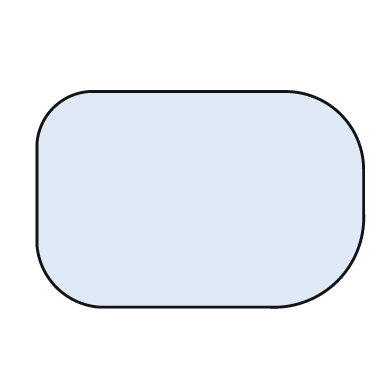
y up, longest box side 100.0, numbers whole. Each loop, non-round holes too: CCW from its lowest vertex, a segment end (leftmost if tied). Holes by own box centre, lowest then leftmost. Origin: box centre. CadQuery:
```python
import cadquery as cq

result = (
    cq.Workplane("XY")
    .moveTo(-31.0, -33.0)
    .lineTo(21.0, -33.0)
    .threePointArc((42.0, -25.0), (50.0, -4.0))
    .lineTo(50.0, 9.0)
    .threePointArc((43.0, 26.0), (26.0, 33.0))
    .lineTo(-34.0, 33.0)
    .threePointArc((-45.0, 28.0), (-50.0, 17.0))
    .lineTo(-50.0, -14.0)
    .threePointArc((-44.0, -27.0), (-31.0, -33.0))
    .close()
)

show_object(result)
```